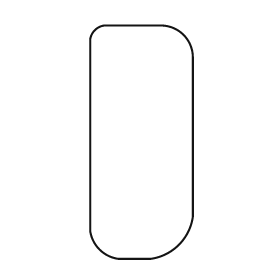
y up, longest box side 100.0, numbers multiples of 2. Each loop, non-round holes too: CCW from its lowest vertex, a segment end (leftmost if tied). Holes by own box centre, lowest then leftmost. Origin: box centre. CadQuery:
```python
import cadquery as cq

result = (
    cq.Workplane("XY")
    .moveTo(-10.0, -50.0)
    .lineTo(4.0, -50.0)
    .threePointArc((16.0, -44.0), (22.0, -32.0))
    .lineTo(22.0, 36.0)
    .threePointArc((18.0, 46.0), (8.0, 50.0))
    .lineTo(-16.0, 50.0)
    .threePointArc((-20.0, 48.0), (-22.0, 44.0))
    .lineTo(-22.0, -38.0)
    .threePointArc((-18.0, -46.0), (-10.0, -50.0))
    .close()
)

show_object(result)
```